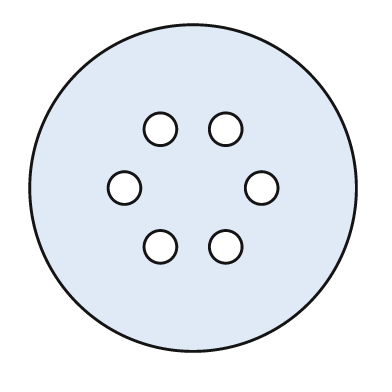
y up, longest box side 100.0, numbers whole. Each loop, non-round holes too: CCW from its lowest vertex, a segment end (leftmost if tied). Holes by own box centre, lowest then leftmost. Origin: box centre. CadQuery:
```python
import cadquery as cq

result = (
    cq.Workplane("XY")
    .moveTo(0.0, 0.0)
    .circle(50.0)
    .moveTo(-10.0, -18.0)
    .circle(5.0)
    .moveTo(10.0, -18.0)
    .circle(5.0)
    .moveTo(-21.0, 0.0)
    .circle(5.0)
    .moveTo(21.0, 0.0)
    .circle(5.0)
    .moveTo(-10.0, 18.0)
    .circle(5.0)
    .moveTo(10.0, 18.0)
    .circle(5.0)
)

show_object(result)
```